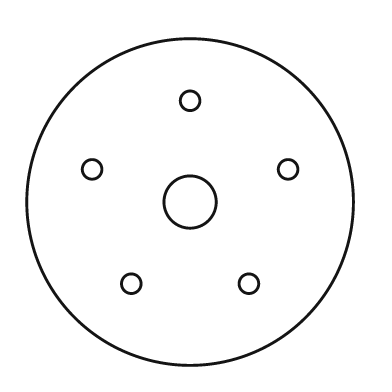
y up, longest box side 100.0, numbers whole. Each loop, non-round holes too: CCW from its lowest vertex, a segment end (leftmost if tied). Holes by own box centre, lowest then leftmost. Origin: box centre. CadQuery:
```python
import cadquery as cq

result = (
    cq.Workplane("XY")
    .moveTo(0.0, 0.0)
    .circle(50.0)
    .moveTo(-18.0, -25.0)
    .circle(3.0)
    .moveTo(18.0, -25.0)
    .circle(3.0)
    .moveTo(0.0, 0.0)
    .circle(8.0)
    .moveTo(-30.0, 10.0)
    .circle(3.0)
    .moveTo(30.0, 10.0)
    .circle(3.0)
    .moveTo(0.0, 31.0)
    .circle(3.0)
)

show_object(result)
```